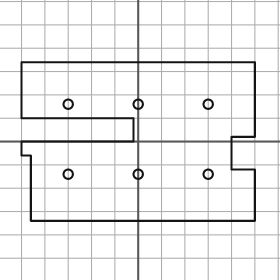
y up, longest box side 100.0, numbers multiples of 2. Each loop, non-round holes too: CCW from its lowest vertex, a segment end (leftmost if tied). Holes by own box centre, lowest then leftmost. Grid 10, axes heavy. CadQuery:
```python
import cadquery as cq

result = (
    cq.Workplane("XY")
    .moveTo(-46.0, -34.0)
    .lineTo(50.0, -34.0)
    .lineTo(50.0, -12.0)
    .lineTo(40.0, -12.0)
    .lineTo(40.0, 2.0)
    .lineTo(50.0, 2.0)
    .lineTo(50.0, 34.0)
    .lineTo(-50.0, 34.0)
    .lineTo(-50.0, 10.0)
    .lineTo(-2.0, 10.0)
    .lineTo(-2.0, 0.0)
    .lineTo(-50.0, 0.0)
    .lineTo(-50.0, -6.0)
    .lineTo(-46.0, -6.0)
    .close()
    .moveTo(-30.0, -14.0)
    .circle(2.0)
    .moveTo(0.0, -14.0)
    .circle(2.0)
    .moveTo(30.0, -14.0)
    .circle(2.0)
    .moveTo(-30.0, 16.0)
    .circle(2.0)
    .moveTo(0.0, 16.0)
    .circle(2.0)
    .moveTo(30.0, 16.0)
    .circle(2.0)
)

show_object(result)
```